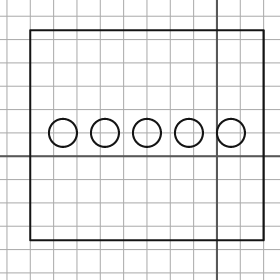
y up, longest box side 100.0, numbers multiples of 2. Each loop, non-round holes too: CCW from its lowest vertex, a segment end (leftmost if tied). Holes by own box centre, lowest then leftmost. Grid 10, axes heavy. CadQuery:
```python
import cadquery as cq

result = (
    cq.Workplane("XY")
    .moveTo(-80.0, -36.0)
    .lineTo(20.0, -36.0)
    .lineTo(20.0, 54.0)
    .lineTo(-80.0, 54.0)
    .close()
    .moveTo(-66.0, 10.0)
    .circle(6.0)
    .moveTo(-48.0, 10.0)
    .circle(6.0)
    .moveTo(-30.0, 10.0)
    .circle(6.0)
    .moveTo(-12.0, 10.0)
    .circle(6.0)
    .moveTo(6.0, 10.0)
    .circle(6.0)
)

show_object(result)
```